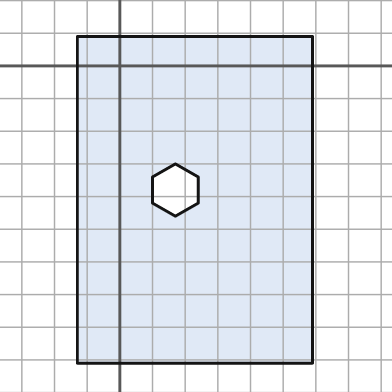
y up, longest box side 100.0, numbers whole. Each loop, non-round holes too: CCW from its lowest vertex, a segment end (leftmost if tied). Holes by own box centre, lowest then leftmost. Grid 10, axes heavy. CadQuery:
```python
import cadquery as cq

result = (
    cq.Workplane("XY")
    .moveTo(-13.0, -91.0)
    .lineTo(59.0, -91.0)
    .lineTo(59.0, 9.0)
    .lineTo(-13.0, 9.0)
    .close()
    .moveTo(17.0, -46.0)
    .lineTo(24.0, -42.0)
    .lineTo(24.0, -34.0)
    .lineTo(17.0, -30.0)
    .lineTo(10.0, -34.0)
    .lineTo(10.0, -42.0)
    .close()
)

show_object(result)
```